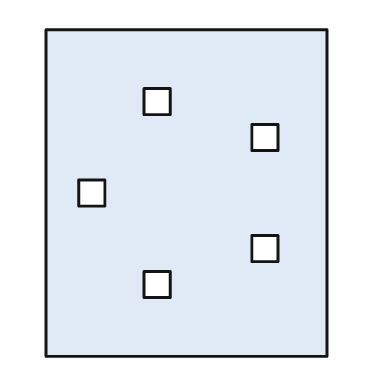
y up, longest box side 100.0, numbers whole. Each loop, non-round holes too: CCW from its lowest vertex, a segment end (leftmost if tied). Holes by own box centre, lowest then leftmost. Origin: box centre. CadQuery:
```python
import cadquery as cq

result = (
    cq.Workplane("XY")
    .moveTo(-43.0, -50.0)
    .lineTo(43.0, -50.0)
    .lineTo(43.0, 50.0)
    .lineTo(-43.0, 50.0)
    .close()
    .moveTo(-13.0, -32.0)
    .lineTo(-5.0, -32.0)
    .lineTo(-5.0, -24.0)
    .lineTo(-13.0, -24.0)
    .close()
    .moveTo(20.0, -21.0)
    .lineTo(28.0, -21.0)
    .lineTo(28.0, -13.0)
    .lineTo(20.0, -13.0)
    .close()
    .moveTo(-33.0, -4.0)
    .lineTo(-25.0, -4.0)
    .lineTo(-25.0, 4.0)
    .lineTo(-33.0, 4.0)
    .close()
    .moveTo(20.0, 13.0)
    .lineTo(28.0, 13.0)
    .lineTo(28.0, 21.0)
    .lineTo(20.0, 21.0)
    .close()
    .moveTo(-13.0, 24.0)
    .lineTo(-5.0, 24.0)
    .lineTo(-5.0, 32.0)
    .lineTo(-13.0, 32.0)
    .close()
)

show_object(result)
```